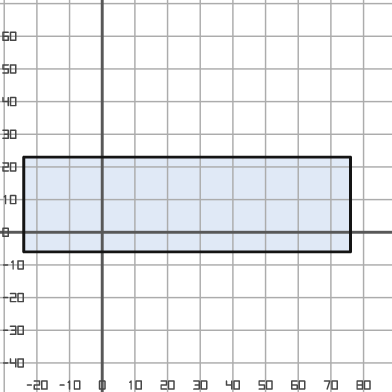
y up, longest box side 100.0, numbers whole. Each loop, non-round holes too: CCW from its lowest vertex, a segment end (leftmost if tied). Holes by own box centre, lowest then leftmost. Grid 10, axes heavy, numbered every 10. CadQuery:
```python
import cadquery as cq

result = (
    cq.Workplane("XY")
    .moveTo(-24.0, -6.0)
    .lineTo(76.0, -6.0)
    .lineTo(76.0, 23.0)
    .lineTo(-24.0, 23.0)
    .close()
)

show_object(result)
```